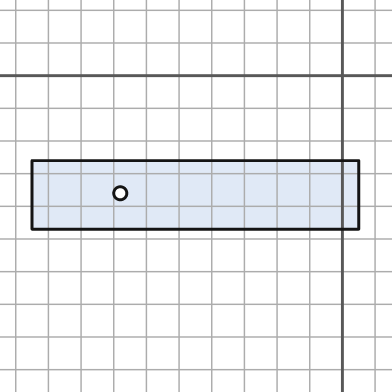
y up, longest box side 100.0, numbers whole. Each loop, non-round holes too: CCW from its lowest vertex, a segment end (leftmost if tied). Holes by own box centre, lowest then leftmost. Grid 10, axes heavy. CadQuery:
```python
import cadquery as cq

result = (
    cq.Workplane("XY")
    .moveTo(-95.0, -47.0)
    .lineTo(5.0, -47.0)
    .lineTo(5.0, -26.0)
    .lineTo(-95.0, -26.0)
    .close()
    .moveTo(-68.0, -36.0)
    .circle(2.0)
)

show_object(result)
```